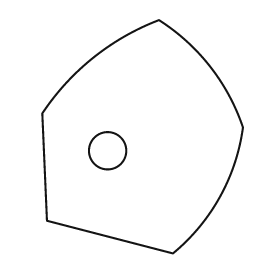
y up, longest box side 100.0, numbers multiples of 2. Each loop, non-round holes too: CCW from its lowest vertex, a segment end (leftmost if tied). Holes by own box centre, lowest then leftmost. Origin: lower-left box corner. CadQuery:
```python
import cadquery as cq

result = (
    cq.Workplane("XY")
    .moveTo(56.0, 0.0)
    .threePointArc((76.0, 24.0), (86.0, 54.0))
    .threePointArc((72.0, 80.0), (50.0, 100.0))
    .threePointArc((22.0, 84.0), (0.0, 60.0))
    .lineTo(2.0, 14.0)
    .close()
    .moveTo(28.0, 44.0)
    .circle(8.0)
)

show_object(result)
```